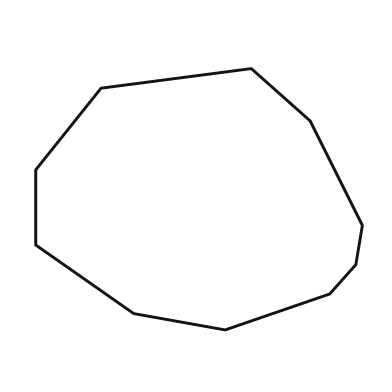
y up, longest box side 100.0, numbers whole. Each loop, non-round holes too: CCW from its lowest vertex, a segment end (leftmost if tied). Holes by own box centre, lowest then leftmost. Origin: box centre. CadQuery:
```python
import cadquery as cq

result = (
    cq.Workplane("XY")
    .moveTo(8.0, -40.0)
    .lineTo(40.0, -29.0)
    .lineTo(48.0, -20.0)
    .lineTo(50.0, -8.0)
    .lineTo(34.0, 24.0)
    .lineTo(16.0, 40.0)
    .lineTo(-30.0, 34.0)
    .lineTo(-50.0, 9.0)
    .lineTo(-50.0, -14.0)
    .lineTo(-20.0, -35.0)
    .close()
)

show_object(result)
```